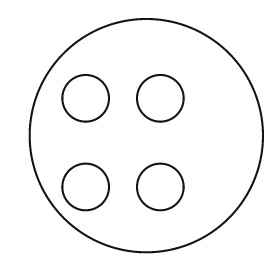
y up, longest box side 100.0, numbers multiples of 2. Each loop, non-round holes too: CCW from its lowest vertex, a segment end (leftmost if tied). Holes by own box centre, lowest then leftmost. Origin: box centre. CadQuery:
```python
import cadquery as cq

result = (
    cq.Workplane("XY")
    .moveTo(0.0, 0.0)
    .circle(50.0)
    .moveTo(-26.0, -22.0)
    .circle(10.0)
    .moveTo(6.0, -22.0)
    .circle(10.0)
    .moveTo(-26.0, 16.0)
    .circle(10.0)
    .moveTo(6.0, 16.0)
    .circle(10.0)
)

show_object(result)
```